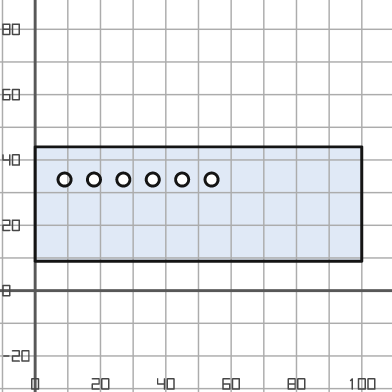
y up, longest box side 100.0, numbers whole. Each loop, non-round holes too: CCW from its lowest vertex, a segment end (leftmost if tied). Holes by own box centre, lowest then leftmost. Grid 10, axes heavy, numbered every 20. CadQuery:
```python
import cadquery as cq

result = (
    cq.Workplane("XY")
    .moveTo(0.0, 9.0)
    .lineTo(100.0, 9.0)
    .lineTo(100.0, 44.0)
    .lineTo(0.0, 44.0)
    .close()
    .moveTo(9.0, 34.0)
    .circle(2.0)
    .moveTo(18.0, 34.0)
    .circle(2.0)
    .moveTo(27.0, 34.0)
    .circle(2.0)
    .moveTo(36.0, 34.0)
    .circle(2.0)
    .moveTo(45.0, 34.0)
    .circle(2.0)
    .moveTo(54.0, 34.0)
    .circle(2.0)
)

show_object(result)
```